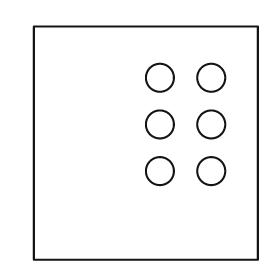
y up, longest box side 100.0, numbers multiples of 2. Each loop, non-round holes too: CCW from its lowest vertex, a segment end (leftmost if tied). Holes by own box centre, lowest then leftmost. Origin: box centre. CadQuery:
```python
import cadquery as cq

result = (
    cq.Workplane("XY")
    .moveTo(-48.0, -50.0)
    .lineTo(48.0, -50.0)
    .lineTo(48.0, 50.0)
    .lineTo(-48.0, 50.0)
    .close()
    .moveTo(6.0, -12.0)
    .circle(6.0)
    .moveTo(28.0, -12.0)
    .circle(6.0)
    .moveTo(6.0, 8.0)
    .circle(6.0)
    .moveTo(28.0, 8.0)
    .circle(6.0)
    .moveTo(6.0, 28.0)
    .circle(6.0)
    .moveTo(28.0, 28.0)
    .circle(6.0)
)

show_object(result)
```